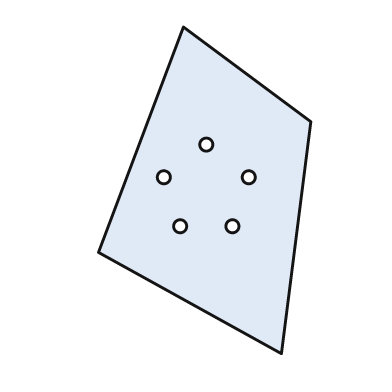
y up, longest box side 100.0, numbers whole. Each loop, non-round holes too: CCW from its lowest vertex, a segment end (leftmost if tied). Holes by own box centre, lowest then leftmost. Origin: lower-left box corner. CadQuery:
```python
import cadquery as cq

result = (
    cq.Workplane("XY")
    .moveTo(56.0, 0.0)
    .lineTo(65.0, 71.0)
    .lineTo(26.0, 100.0)
    .lineTo(0.0, 31.0)
    .close()
    .moveTo(25.0, 39.0)
    .circle(2.0)
    .moveTo(41.0, 39.0)
    .circle(2.0)
    .moveTo(20.0, 54.0)
    .circle(2.0)
    .moveTo(46.0, 54.0)
    .circle(2.0)
    .moveTo(33.0, 64.0)
    .circle(2.0)
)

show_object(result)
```